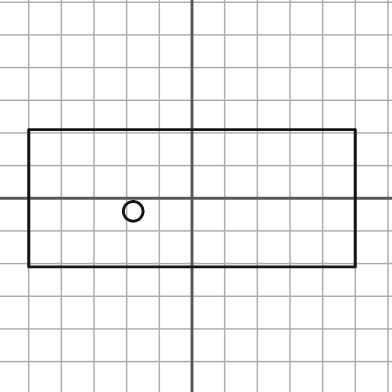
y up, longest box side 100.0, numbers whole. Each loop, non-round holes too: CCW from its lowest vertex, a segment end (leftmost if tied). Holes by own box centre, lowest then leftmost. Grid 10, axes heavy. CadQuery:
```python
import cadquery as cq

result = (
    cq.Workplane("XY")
    .moveTo(-50.0, -21.0)
    .lineTo(50.0, -21.0)
    .lineTo(50.0, 21.0)
    .lineTo(-50.0, 21.0)
    .close()
    .moveTo(-18.0, -4.0)
    .circle(3.0)
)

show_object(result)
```